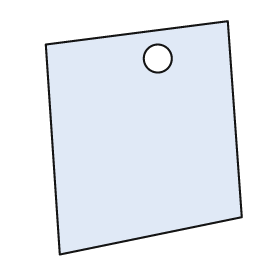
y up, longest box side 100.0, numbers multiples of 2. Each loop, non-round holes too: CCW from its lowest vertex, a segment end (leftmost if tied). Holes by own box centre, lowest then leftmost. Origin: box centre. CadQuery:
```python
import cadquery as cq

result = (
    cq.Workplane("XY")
    .moveTo(-36.0, -50.0)
    .lineTo(42.0, -34.0)
    .lineTo(36.0, 50.0)
    .lineTo(-42.0, 40.0)
    .close()
    .moveTo(6.0, 34.0)
    .circle(6.0)
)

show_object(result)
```